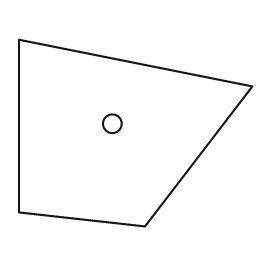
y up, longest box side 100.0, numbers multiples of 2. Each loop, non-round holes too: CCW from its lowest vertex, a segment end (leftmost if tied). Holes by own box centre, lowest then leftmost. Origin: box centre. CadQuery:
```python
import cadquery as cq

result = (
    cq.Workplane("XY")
    .moveTo(4.0, -40.0)
    .lineTo(50.0, 20.0)
    .lineTo(-50.0, 40.0)
    .lineTo(-50.0, -34.0)
    .close()
    .moveTo(-10.0, 4.0)
    .circle(4.0)
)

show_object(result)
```